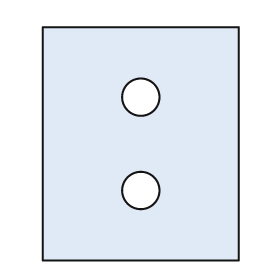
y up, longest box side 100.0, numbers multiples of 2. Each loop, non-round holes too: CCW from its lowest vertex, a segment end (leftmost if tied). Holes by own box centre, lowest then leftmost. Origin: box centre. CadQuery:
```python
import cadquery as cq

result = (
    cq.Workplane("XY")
    .moveTo(-42.0, -50.0)
    .lineTo(42.0, -50.0)
    .lineTo(42.0, 50.0)
    .lineTo(-42.0, 50.0)
    .close()
    .moveTo(0.0, -20.0)
    .circle(8.0)
    .moveTo(0.0, 20.0)
    .circle(8.0)
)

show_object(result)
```